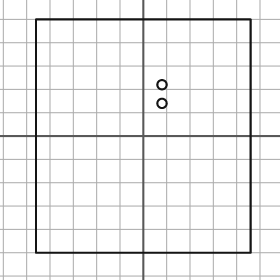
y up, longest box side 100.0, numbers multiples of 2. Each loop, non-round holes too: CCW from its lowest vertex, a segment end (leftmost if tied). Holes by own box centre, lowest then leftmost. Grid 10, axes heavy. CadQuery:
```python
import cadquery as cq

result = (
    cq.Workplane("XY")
    .moveTo(-46.0, -50.0)
    .lineTo(46.0, -50.0)
    .lineTo(46.0, 50.0)
    .lineTo(-46.0, 50.0)
    .close()
    .moveTo(8.0, 14.0)
    .circle(2.0)
    .moveTo(8.0, 22.0)
    .circle(2.0)
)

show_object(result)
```